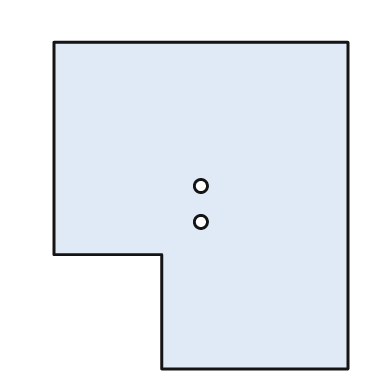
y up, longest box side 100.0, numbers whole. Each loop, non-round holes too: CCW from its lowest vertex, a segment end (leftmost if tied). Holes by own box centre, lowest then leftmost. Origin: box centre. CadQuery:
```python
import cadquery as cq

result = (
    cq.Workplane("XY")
    .moveTo(-12.0, -50.0)
    .lineTo(45.0, -50.0)
    .lineTo(45.0, 50.0)
    .lineTo(-45.0, 50.0)
    .lineTo(-45.0, -15.0)
    .lineTo(-12.0, -15.0)
    .close()
    .moveTo(0.0, -5.0)
    .circle(2.0)
    .moveTo(0.0, 6.0)
    .circle(2.0)
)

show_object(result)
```